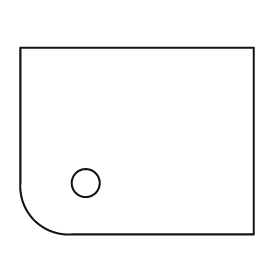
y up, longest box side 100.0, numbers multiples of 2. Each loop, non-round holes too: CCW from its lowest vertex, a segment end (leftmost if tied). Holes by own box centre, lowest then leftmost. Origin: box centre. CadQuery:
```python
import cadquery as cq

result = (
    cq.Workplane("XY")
    .moveTo(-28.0, -40.0)
    .lineTo(50.0, -40.0)
    .lineTo(50.0, 40.0)
    .lineTo(-50.0, 40.0)
    .lineTo(-50.0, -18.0)
    .threePointArc((-44.0, -34.0), (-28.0, -40.0))
    .close()
    .moveTo(-22.0, -18.0)
    .circle(6.0)
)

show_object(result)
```